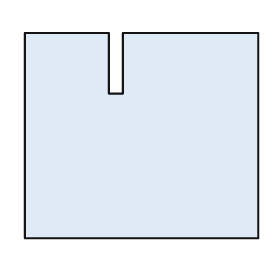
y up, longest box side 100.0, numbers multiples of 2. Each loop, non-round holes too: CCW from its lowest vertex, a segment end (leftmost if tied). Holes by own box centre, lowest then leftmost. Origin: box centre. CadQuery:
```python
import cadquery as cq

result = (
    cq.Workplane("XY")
    .moveTo(-50.0, -44.0)
    .lineTo(50.0, -44.0)
    .lineTo(50.0, 44.0)
    .lineTo(-8.0, 44.0)
    .lineTo(-8.0, 18.0)
    .lineTo(-14.0, 18.0)
    .lineTo(-14.0, 44.0)
    .lineTo(-50.0, 44.0)
    .close()
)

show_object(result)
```